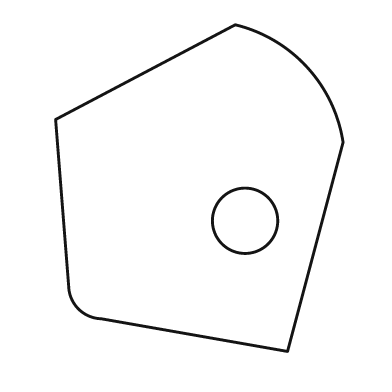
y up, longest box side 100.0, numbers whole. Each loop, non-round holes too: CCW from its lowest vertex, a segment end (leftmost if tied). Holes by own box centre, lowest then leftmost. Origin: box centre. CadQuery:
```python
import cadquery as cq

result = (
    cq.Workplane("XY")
    .moveTo(27.0, -50.0)
    .lineTo(44.0, 14.0)
    .threePointArc((33.0, 37.0), (11.0, 50.0))
    .lineTo(-44.0, 21.0)
    .lineTo(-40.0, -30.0)
    .threePointArc((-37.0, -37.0), (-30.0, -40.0))
    .close()
    .moveTo(14.0, -10.0)
    .circle(10.0)
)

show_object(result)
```